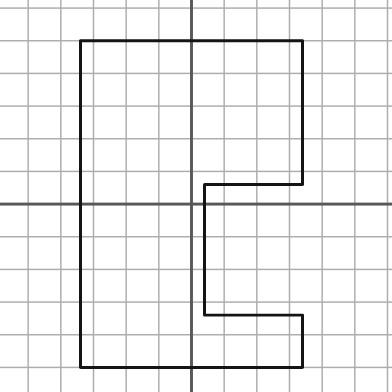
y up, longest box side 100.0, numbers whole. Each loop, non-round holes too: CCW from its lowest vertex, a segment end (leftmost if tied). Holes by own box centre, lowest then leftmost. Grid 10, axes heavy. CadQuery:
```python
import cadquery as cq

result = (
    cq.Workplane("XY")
    .moveTo(-34.0, -50.0)
    .lineTo(34.0, -50.0)
    .lineTo(34.0, -34.0)
    .lineTo(4.0, -34.0)
    .lineTo(4.0, 6.0)
    .lineTo(34.0, 6.0)
    .lineTo(34.0, 50.0)
    .lineTo(-34.0, 50.0)
    .close()
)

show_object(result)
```